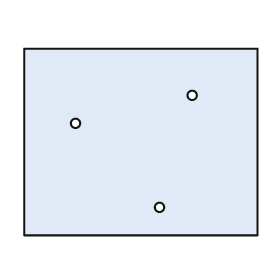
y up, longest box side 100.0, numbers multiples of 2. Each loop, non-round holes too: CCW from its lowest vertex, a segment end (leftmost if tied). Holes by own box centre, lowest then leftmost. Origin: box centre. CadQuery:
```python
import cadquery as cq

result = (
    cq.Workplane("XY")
    .moveTo(-50.0, -40.0)
    .lineTo(50.0, -40.0)
    .lineTo(50.0, 40.0)
    .lineTo(-50.0, 40.0)
    .close()
    .moveTo(8.0, -28.0)
    .circle(2.0)
    .moveTo(-28.0, 8.0)
    .circle(2.0)
    .moveTo(22.0, 20.0)
    .circle(2.0)
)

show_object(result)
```